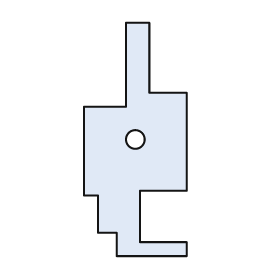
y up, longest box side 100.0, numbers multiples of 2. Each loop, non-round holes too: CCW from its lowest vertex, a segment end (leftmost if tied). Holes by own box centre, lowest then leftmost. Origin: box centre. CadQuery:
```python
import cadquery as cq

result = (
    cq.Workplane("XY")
    .moveTo(-8.0, -50.0)
    .lineTo(22.0, -50.0)
    .lineTo(22.0, -44.0)
    .lineTo(2.0, -44.0)
    .lineTo(2.0, -22.0)
    .lineTo(22.0, -22.0)
    .lineTo(22.0, 20.0)
    .lineTo(6.0, 20.0)
    .lineTo(6.0, 50.0)
    .lineTo(-4.0, 50.0)
    .lineTo(-4.0, 14.0)
    .lineTo(-22.0, 14.0)
    .lineTo(-22.0, -24.0)
    .lineTo(-16.0, -24.0)
    .lineTo(-16.0, -40.0)
    .lineTo(-8.0, -40.0)
    .close()
    .moveTo(0.0, 0.0)
    .circle(4.0)
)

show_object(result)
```